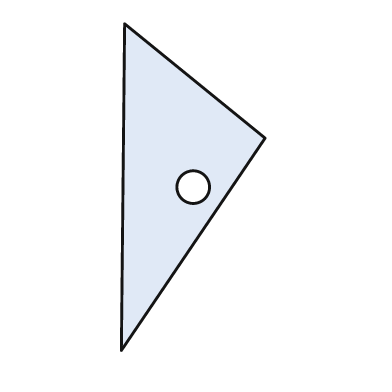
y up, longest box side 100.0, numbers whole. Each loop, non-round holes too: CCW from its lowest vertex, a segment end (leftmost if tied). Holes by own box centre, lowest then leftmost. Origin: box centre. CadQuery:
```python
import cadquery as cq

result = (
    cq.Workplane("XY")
    .moveTo(-22.0, -50.0)
    .lineTo(22.0, 15.0)
    .lineTo(-21.0, 50.0)
    .close()
    .moveTo(0.0, 0.0)
    .circle(5.0)
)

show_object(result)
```